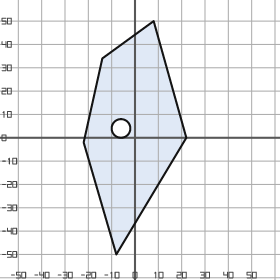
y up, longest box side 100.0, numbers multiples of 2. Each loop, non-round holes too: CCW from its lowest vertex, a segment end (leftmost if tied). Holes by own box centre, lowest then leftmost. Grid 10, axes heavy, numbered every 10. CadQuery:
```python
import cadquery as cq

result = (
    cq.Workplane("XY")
    .moveTo(-8.0, -50.0)
    .lineTo(22.0, 0.0)
    .lineTo(8.0, 50.0)
    .lineTo(-14.0, 34.0)
    .lineTo(-22.0, -2.0)
    .close()
    .moveTo(-6.0, 4.0)
    .circle(4.0)
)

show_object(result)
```